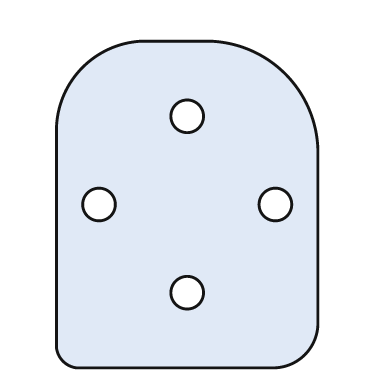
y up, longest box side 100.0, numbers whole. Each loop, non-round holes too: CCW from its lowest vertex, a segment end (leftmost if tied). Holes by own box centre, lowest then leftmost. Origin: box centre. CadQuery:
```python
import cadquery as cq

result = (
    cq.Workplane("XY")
    .moveTo(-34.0, -50.0)
    .lineTo(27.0, -50.0)
    .threePointArc((36.0, -46.0), (40.0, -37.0))
    .lineTo(40.0, 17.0)
    .threePointArc((30.0, 40.0), (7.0, 50.0))
    .lineTo(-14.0, 50.0)
    .threePointArc((-32.0, 42.0), (-40.0, 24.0))
    .lineTo(-40.0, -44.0)
    .threePointArc((-38.0, -48.0), (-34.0, -50.0))
    .close()
    .moveTo(0.0, -27.0)
    .circle(5.0)
    .moveTo(-27.0, 0.0)
    .circle(5.0)
    .moveTo(27.0, 0.0)
    .circle(5.0)
    .moveTo(0.0, 27.0)
    .circle(5.0)
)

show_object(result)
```